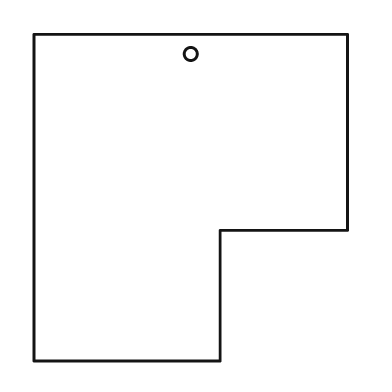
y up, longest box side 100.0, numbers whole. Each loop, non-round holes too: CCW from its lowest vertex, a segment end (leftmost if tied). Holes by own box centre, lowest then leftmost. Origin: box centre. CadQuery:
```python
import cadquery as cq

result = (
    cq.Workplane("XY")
    .moveTo(-48.0, -50.0)
    .lineTo(9.0, -50.0)
    .lineTo(9.0, -10.0)
    .lineTo(48.0, -10.0)
    .lineTo(48.0, 50.0)
    .lineTo(-48.0, 50.0)
    .close()
    .moveTo(0.0, 44.0)
    .circle(2.0)
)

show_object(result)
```